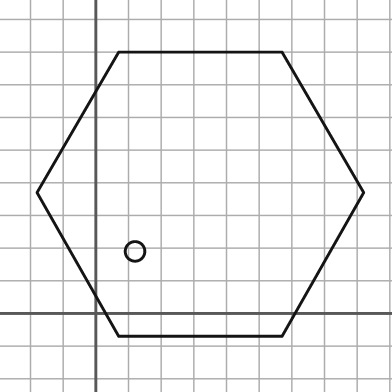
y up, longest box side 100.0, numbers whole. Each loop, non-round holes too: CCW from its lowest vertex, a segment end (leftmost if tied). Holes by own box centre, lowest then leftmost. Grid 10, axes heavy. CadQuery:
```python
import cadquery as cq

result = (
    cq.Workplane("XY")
    .moveTo(7.0, -7.0)
    .lineTo(57.0, -7.0)
    .lineTo(82.0, 37.0)
    .lineTo(57.0, 80.0)
    .lineTo(7.0, 80.0)
    .lineTo(-18.0, 37.0)
    .close()
    .moveTo(12.0, 19.0)
    .circle(3.0)
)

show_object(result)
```